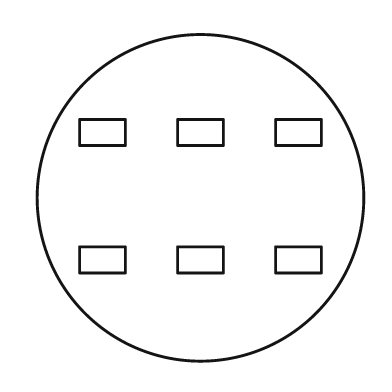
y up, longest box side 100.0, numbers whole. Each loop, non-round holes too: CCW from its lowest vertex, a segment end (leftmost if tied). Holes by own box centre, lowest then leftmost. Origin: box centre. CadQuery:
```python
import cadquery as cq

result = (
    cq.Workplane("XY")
    .moveTo(0.0, 0.0)
    .circle(50.0)
    .moveTo(-37.0, -23.0)
    .lineTo(-23.0, -23.0)
    .lineTo(-23.0, -15.0)
    .lineTo(-37.0, -15.0)
    .close()
    .moveTo(-7.0, -23.0)
    .lineTo(7.0, -23.0)
    .lineTo(7.0, -15.0)
    .lineTo(-7.0, -15.0)
    .close()
    .moveTo(23.0, -23.0)
    .lineTo(37.0, -23.0)
    .lineTo(37.0, -15.0)
    .lineTo(23.0, -15.0)
    .close()
    .moveTo(-37.0, 16.0)
    .lineTo(-23.0, 16.0)
    .lineTo(-23.0, 24.0)
    .lineTo(-37.0, 24.0)
    .close()
    .moveTo(-7.0, 16.0)
    .lineTo(7.0, 16.0)
    .lineTo(7.0, 24.0)
    .lineTo(-7.0, 24.0)
    .close()
    .moveTo(23.0, 16.0)
    .lineTo(37.0, 16.0)
    .lineTo(37.0, 24.0)
    .lineTo(23.0, 24.0)
    .close()
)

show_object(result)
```